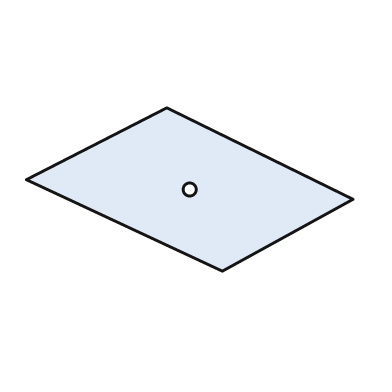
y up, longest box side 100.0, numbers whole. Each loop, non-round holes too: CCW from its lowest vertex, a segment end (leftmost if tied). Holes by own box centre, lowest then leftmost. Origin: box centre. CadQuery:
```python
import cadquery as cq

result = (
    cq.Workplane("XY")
    .moveTo(10.0, -25.0)
    .lineTo(50.0, -3.0)
    .lineTo(-7.0, 25.0)
    .lineTo(-50.0, 3.0)
    .close()
    .moveTo(0.0, 0.0)
    .circle(2.0)
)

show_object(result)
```